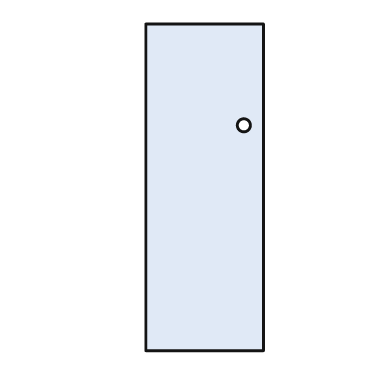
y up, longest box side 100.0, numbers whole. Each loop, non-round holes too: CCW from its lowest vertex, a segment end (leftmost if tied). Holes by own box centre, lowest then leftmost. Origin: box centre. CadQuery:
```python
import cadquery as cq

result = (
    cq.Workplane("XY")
    .moveTo(-18.0, -50.0)
    .lineTo(18.0, -50.0)
    .lineTo(18.0, 50.0)
    .lineTo(-18.0, 50.0)
    .close()
    .moveTo(12.0, 19.0)
    .circle(2.0)
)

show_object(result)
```